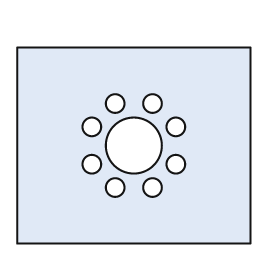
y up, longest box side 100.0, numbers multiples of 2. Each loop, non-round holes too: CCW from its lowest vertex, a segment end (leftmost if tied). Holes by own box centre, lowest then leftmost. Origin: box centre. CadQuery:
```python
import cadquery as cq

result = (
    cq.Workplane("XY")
    .moveTo(-50.0, -42.0)
    .lineTo(50.0, -42.0)
    .lineTo(50.0, 42.0)
    .lineTo(-50.0, 42.0)
    .close()
    .moveTo(-8.0, -18.0)
    .circle(4.0)
    .moveTo(8.0, -18.0)
    .circle(4.0)
    .moveTo(-18.0, -8.0)
    .circle(4.0)
    .moveTo(18.0, -8.0)
    .circle(4.0)
    .moveTo(0.0, 0.0)
    .circle(12.0)
    .moveTo(-18.0, 8.0)
    .circle(4.0)
    .moveTo(18.0, 8.0)
    .circle(4.0)
    .moveTo(-8.0, 18.0)
    .circle(4.0)
    .moveTo(8.0, 18.0)
    .circle(4.0)
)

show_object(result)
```